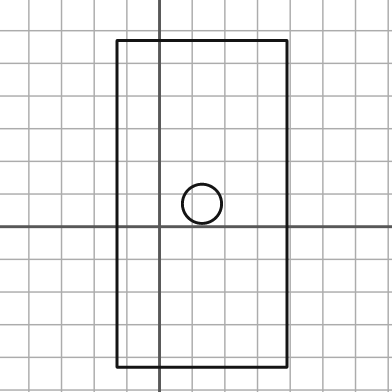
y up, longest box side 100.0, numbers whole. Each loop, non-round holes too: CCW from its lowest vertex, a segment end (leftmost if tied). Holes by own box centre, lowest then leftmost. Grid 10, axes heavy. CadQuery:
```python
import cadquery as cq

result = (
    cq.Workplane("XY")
    .moveTo(-13.0, -43.0)
    .lineTo(39.0, -43.0)
    .lineTo(39.0, 57.0)
    .lineTo(-13.0, 57.0)
    .close()
    .moveTo(13.0, 7.0)
    .circle(6.0)
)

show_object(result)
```